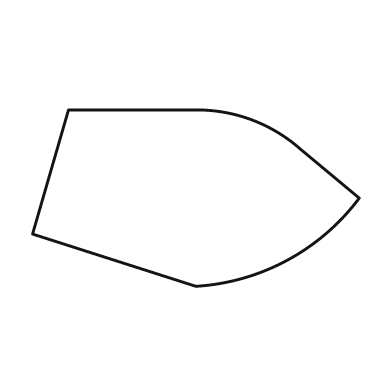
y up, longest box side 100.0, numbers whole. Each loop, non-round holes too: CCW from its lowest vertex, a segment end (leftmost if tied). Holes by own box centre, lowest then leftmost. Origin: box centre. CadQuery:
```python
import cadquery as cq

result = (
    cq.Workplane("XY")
    .moveTo(0.0, -27.0)
    .threePointArc((28.0, -19.0), (50.0, 0.0))
    .lineTo(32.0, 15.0)
    .threePointArc((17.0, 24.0), (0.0, 27.0))
    .lineTo(-39.0, 27.0)
    .lineTo(-50.0, -11.0)
    .close()
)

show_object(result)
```